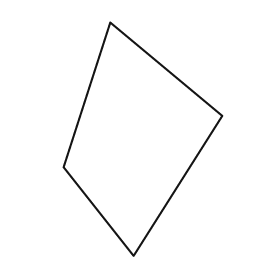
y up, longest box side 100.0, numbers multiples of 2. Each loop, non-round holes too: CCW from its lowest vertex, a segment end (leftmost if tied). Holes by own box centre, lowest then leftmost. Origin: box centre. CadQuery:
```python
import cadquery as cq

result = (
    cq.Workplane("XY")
    .moveTo(-4.0, -50.0)
    .lineTo(34.0, 10.0)
    .lineTo(-14.0, 50.0)
    .lineTo(-34.0, -12.0)
    .close()
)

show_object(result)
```